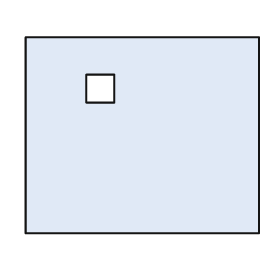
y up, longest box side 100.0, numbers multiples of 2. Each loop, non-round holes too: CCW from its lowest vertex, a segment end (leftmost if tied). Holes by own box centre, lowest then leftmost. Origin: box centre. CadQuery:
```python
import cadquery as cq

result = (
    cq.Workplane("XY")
    .moveTo(-50.0, -42.0)
    .lineTo(50.0, -42.0)
    .lineTo(50.0, 42.0)
    .lineTo(-50.0, 42.0)
    .close()
    .moveTo(-24.0, 14.0)
    .lineTo(-12.0, 14.0)
    .lineTo(-12.0, 26.0)
    .lineTo(-24.0, 26.0)
    .close()
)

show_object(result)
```